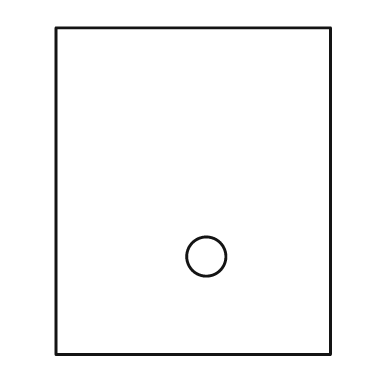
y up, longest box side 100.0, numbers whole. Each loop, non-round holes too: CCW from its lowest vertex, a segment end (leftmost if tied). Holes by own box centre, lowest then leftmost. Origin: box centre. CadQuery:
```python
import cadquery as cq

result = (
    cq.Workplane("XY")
    .moveTo(-42.0, -50.0)
    .lineTo(42.0, -50.0)
    .lineTo(42.0, 50.0)
    .lineTo(-42.0, 50.0)
    .close()
    .moveTo(4.0, -20.0)
    .circle(6.0)
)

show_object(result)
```